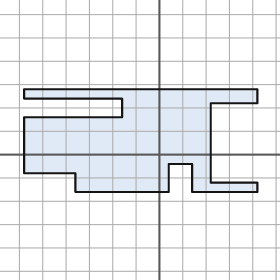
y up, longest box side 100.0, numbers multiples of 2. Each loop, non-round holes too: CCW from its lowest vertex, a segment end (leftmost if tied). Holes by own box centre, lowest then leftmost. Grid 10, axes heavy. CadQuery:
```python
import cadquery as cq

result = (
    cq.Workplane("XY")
    .moveTo(-36.0, -16.0)
    .lineTo(4.0, -16.0)
    .lineTo(4.0, -4.0)
    .lineTo(14.0, -4.0)
    .lineTo(14.0, -16.0)
    .lineTo(42.0, -16.0)
    .lineTo(42.0, -12.0)
    .lineTo(22.0, -12.0)
    .lineTo(22.0, 22.0)
    .lineTo(42.0, 22.0)
    .lineTo(42.0, 28.0)
    .lineTo(-58.0, 28.0)
    .lineTo(-58.0, 24.0)
    .lineTo(-16.0, 24.0)
    .lineTo(-16.0, 16.0)
    .lineTo(-58.0, 16.0)
    .lineTo(-58.0, -8.0)
    .lineTo(-36.0, -8.0)
    .close()
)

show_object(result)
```